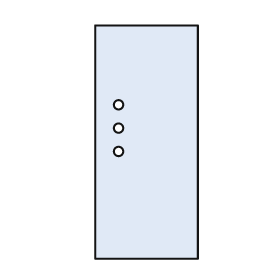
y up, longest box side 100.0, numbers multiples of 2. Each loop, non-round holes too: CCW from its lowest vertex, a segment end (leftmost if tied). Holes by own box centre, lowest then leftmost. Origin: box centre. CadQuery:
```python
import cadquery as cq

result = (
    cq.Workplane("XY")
    .moveTo(-22.0, -50.0)
    .lineTo(22.0, -50.0)
    .lineTo(22.0, 50.0)
    .lineTo(-22.0, 50.0)
    .close()
    .moveTo(-12.0, -4.0)
    .circle(2.0)
    .moveTo(-12.0, 6.0)
    .circle(2.0)
    .moveTo(-12.0, 16.0)
    .circle(2.0)
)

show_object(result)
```